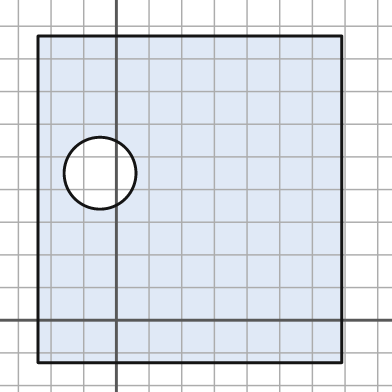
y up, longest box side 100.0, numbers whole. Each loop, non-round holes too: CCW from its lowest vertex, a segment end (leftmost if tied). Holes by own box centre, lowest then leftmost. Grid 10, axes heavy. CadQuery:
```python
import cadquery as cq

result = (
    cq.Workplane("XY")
    .moveTo(-24.0, -13.0)
    .lineTo(69.0, -13.0)
    .lineTo(69.0, 87.0)
    .lineTo(-24.0, 87.0)
    .close()
    .moveTo(-5.0, 45.0)
    .circle(11.0)
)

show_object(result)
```